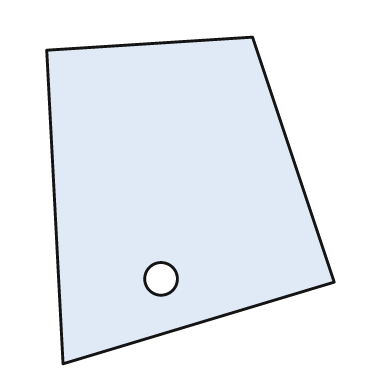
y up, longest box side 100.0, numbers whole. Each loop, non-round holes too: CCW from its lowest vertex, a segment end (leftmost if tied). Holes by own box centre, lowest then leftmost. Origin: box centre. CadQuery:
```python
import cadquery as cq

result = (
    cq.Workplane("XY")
    .moveTo(-39.0, -50.0)
    .lineTo(44.0, -25.0)
    .lineTo(19.0, 50.0)
    .lineTo(-44.0, 46.0)
    .close()
    .moveTo(-9.0, -24.0)
    .circle(5.0)
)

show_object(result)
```